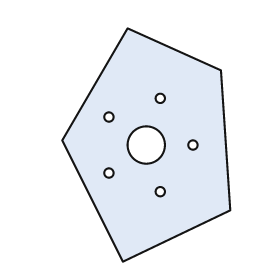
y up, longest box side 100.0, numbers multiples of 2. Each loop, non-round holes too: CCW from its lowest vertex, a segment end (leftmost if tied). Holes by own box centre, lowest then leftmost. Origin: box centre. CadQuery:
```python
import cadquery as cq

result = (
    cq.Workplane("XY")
    .moveTo(-10.0, -50.0)
    .lineTo(36.0, -28.0)
    .lineTo(32.0, 32.0)
    .lineTo(-8.0, 50.0)
    .lineTo(-36.0, 2.0)
    .close()
    .moveTo(6.0, -20.0)
    .circle(2.0)
    .moveTo(-16.0, -12.0)
    .circle(2.0)
    .moveTo(0.0, 0.0)
    .circle(8.0)
    .moveTo(20.0, 0.0)
    .circle(2.0)
    .moveTo(-16.0, 12.0)
    .circle(2.0)
    .moveTo(6.0, 20.0)
    .circle(2.0)
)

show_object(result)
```